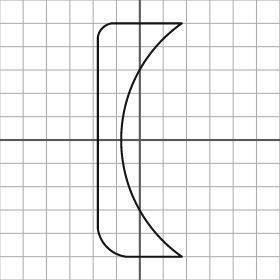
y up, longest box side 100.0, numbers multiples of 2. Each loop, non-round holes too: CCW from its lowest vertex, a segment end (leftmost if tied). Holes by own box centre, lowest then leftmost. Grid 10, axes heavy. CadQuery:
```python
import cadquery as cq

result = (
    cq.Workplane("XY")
    .moveTo(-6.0, -50.0)
    .lineTo(18.0, -50.0)
    .threePointArc((-8.0, 0.0), (18.0, 50.0))
    .lineTo(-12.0, 50.0)
    .threePointArc((-16.0, 48.0), (-18.0, 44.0))
    .lineTo(-18.0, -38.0)
    .threePointArc((-14.0, -46.0), (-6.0, -50.0))
    .close()
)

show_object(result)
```